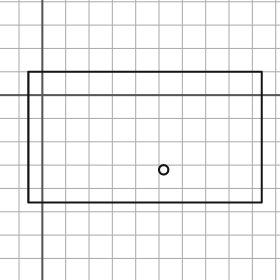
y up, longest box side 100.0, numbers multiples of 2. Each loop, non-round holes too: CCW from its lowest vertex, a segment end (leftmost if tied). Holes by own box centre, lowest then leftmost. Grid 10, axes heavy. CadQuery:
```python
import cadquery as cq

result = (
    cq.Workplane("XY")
    .moveTo(-6.0, -46.0)
    .lineTo(94.0, -46.0)
    .lineTo(94.0, 10.0)
    .lineTo(-6.0, 10.0)
    .close()
    .moveTo(52.0, -32.0)
    .circle(2.0)
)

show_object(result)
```